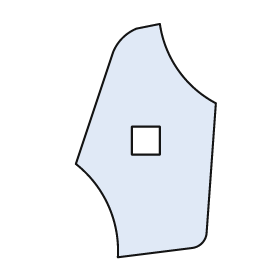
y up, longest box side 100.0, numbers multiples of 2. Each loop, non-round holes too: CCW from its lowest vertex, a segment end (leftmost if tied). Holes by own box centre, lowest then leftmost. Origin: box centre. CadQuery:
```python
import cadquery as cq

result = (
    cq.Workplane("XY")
    .moveTo(-12.0, -50.0)
    .lineTo(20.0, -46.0)
    .threePointArc((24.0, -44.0), (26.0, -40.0))
    .lineTo(30.0, 16.0)
    .threePointArc((14.0, 30.0), (6.0, 50.0))
    .lineTo(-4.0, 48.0)
    .threePointArc((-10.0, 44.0), (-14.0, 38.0))
    .lineTo(-30.0, -10.0)
    .threePointArc((-16.0, -28.0), (-12.0, -50.0))
    .close()
    .moveTo(-6.0, -6.0)
    .lineTo(6.0, -6.0)
    .lineTo(6.0, 6.0)
    .lineTo(-6.0, 6.0)
    .close()
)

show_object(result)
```